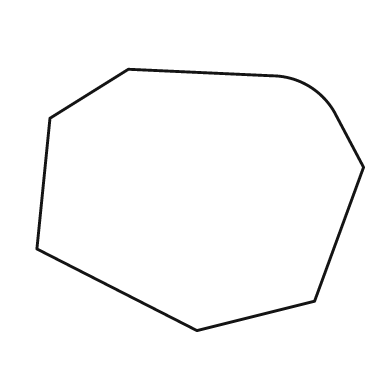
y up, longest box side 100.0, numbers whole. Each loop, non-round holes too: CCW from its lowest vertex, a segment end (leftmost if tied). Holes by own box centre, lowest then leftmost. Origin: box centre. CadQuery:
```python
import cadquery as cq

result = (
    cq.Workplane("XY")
    .moveTo(-1.0, -40.0)
    .lineTo(35.0, -31.0)
    .lineTo(50.0, 10.0)
    .lineTo(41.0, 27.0)
    .threePointArc((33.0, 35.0), (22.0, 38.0))
    .lineTo(-22.0, 40.0)
    .lineTo(-46.0, 25.0)
    .lineTo(-50.0, -15.0)
    .close()
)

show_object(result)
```